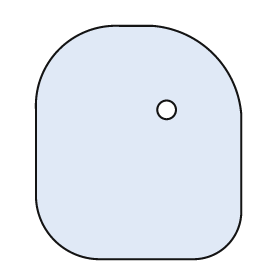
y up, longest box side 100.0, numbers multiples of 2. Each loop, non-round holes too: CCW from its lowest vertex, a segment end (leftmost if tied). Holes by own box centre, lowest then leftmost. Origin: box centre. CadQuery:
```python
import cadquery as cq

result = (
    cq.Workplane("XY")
    .moveTo(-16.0, -50.0)
    .lineTo(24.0, -50.0)
    .threePointArc((38.0, -44.0), (44.0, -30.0))
    .lineTo(44.0, 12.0)
    .threePointArc((32.0, 38.0), (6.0, 50.0))
    .lineTo(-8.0, 50.0)
    .threePointArc((-34.0, 40.0), (-44.0, 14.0))
    .lineTo(-44.0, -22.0)
    .threePointArc((-36.0, -42.0), (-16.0, -50.0))
    .close()
    .moveTo(12.0, 14.0)
    .circle(4.0)
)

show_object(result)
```